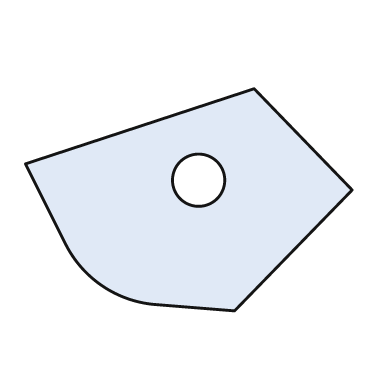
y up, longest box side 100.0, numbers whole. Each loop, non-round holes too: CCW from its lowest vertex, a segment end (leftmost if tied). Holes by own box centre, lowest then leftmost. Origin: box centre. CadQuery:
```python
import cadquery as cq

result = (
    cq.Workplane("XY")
    .moveTo(14.0, -34.0)
    .lineTo(50.0, 3.0)
    .lineTo(20.0, 34.0)
    .lineTo(-50.0, 11.0)
    .lineTo(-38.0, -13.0)
    .threePointArc((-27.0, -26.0), (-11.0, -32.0))
    .close()
    .moveTo(3.0, 6.0)
    .circle(8.0)
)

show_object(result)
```